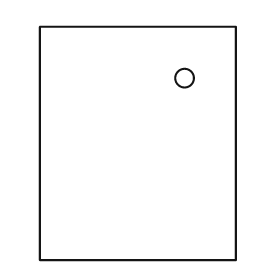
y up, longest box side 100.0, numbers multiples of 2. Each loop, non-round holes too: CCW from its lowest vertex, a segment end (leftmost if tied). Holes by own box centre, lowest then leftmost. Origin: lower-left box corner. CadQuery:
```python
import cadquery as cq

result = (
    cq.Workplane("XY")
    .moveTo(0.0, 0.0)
    .lineTo(84.0, 0.0)
    .lineTo(84.0, 100.0)
    .lineTo(0.0, 100.0)
    .close()
    .moveTo(62.0, 78.0)
    .circle(4.0)
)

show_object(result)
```